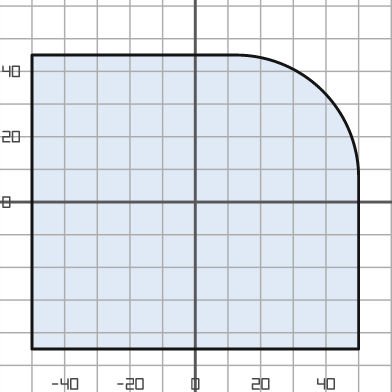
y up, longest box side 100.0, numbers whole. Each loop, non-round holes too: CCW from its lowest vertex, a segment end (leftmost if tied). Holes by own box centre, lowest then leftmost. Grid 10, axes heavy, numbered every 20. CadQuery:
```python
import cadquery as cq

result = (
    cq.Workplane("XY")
    .moveTo(-50.0, -45.0)
    .lineTo(50.0, -45.0)
    .lineTo(50.0, 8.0)
    .threePointArc((39.0, 34.0), (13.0, 45.0))
    .lineTo(-50.0, 45.0)
    .close()
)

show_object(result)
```